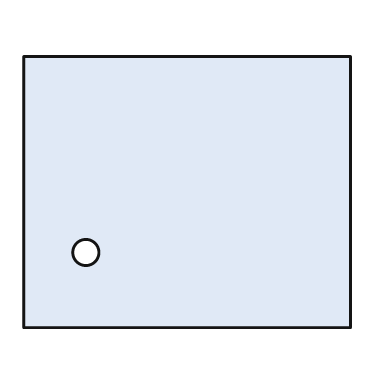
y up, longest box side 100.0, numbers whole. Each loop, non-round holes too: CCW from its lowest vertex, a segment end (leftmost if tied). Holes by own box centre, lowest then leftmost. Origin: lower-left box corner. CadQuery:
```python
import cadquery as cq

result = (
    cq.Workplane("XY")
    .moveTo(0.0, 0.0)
    .lineTo(100.0, 0.0)
    .lineTo(100.0, 83.0)
    .lineTo(0.0, 83.0)
    .close()
    .moveTo(19.0, 23.0)
    .circle(4.0)
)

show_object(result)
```